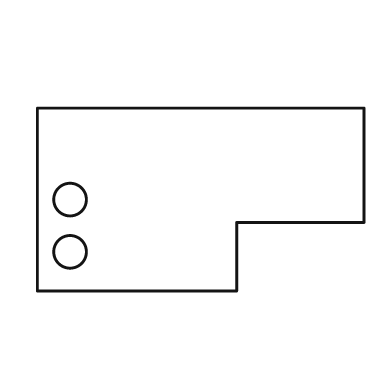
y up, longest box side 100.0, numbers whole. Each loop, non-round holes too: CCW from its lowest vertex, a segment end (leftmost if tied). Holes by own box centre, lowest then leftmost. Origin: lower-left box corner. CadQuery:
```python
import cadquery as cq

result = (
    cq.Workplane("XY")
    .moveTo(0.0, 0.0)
    .lineTo(61.0, 0.0)
    .lineTo(61.0, 21.0)
    .lineTo(100.0, 21.0)
    .lineTo(100.0, 56.0)
    .lineTo(0.0, 56.0)
    .close()
    .moveTo(10.0, 12.0)
    .circle(5.0)
    .moveTo(10.0, 28.0)
    .circle(5.0)
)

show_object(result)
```